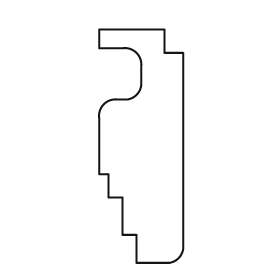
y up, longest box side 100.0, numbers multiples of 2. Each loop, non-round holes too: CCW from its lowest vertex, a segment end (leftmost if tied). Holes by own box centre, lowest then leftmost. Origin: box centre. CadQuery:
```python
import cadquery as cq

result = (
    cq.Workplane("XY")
    .moveTo(-2.0, -50.0)
    .lineTo(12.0, -50.0)
    .threePointArc((16.0, -48.0), (18.0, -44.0))
    .lineTo(18.0, 40.0)
    .lineTo(10.0, 40.0)
    .lineTo(10.0, 50.0)
    .lineTo(-18.0, 50.0)
    .lineTo(-18.0, 42.0)
    .lineTo(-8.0, 42.0)
    .threePointArc((-2.0, 40.0), (0.0, 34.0))
    .lineTo(0.0, 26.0)
    .threePointArc((-2.0, 22.0), (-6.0, 20.0))
    .lineTo(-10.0, 20.0)
    .threePointArc((-16.0, 18.0), (-18.0, 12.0))
    .lineTo(-18.0, -12.0)
    .lineTo(-14.0, -12.0)
    .lineTo(-14.0, -22.0)
    .lineTo(-8.0, -22.0)
    .lineTo(-8.0, -38.0)
    .lineTo(-2.0, -38.0)
    .close()
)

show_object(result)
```